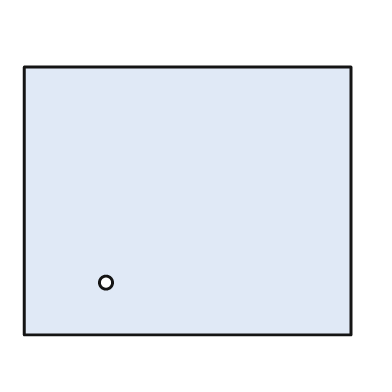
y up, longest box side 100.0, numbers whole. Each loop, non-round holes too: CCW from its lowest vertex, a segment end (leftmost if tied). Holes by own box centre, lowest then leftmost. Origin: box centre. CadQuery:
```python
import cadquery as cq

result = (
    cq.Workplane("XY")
    .moveTo(-50.0, -41.0)
    .lineTo(50.0, -41.0)
    .lineTo(50.0, 41.0)
    .lineTo(-50.0, 41.0)
    .close()
    .moveTo(-25.0, -25.0)
    .circle(2.0)
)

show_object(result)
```